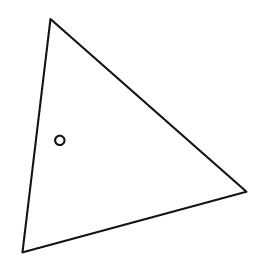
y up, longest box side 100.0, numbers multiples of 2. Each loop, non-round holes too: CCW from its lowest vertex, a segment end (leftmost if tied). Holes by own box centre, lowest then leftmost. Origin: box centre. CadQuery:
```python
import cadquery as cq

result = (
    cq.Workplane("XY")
    .moveTo(-48.0, -50.0)
    .lineTo(48.0, -24.0)
    .lineTo(-36.0, 50.0)
    .close()
    .moveTo(-32.0, -2.0)
    .circle(2.0)
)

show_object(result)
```